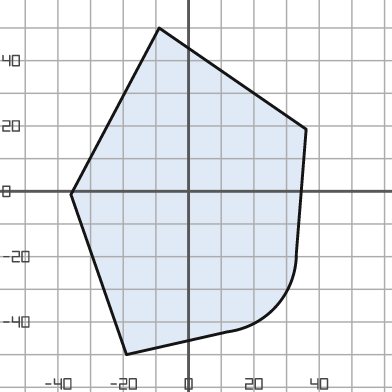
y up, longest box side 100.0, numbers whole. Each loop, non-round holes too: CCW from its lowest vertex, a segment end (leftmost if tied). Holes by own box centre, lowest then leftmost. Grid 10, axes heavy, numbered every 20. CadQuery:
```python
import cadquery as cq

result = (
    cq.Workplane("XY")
    .moveTo(-19.0, -50.0)
    .lineTo(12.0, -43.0)
    .threePointArc((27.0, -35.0), (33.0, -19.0))
    .lineTo(36.0, 19.0)
    .lineTo(-9.0, 50.0)
    .lineTo(-36.0, -1.0)
    .close()
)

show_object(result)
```